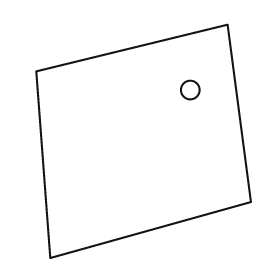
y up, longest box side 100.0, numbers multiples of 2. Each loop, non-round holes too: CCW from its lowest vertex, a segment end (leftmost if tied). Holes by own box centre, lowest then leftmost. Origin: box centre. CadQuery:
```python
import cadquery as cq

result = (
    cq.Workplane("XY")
    .moveTo(-40.0, -50.0)
    .lineTo(46.0, -26.0)
    .lineTo(36.0, 50.0)
    .lineTo(-46.0, 30.0)
    .close()
    .moveTo(20.0, 22.0)
    .circle(4.0)
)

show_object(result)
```